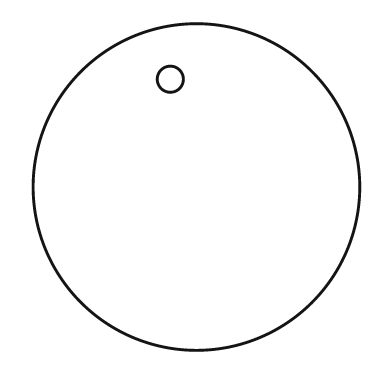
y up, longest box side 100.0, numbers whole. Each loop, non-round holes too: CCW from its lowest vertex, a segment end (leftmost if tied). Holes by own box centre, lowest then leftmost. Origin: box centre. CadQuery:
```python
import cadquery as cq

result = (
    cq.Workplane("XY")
    .moveTo(0.0, 0.0)
    .circle(50.0)
    .moveTo(-8.0, 33.0)
    .circle(4.0)
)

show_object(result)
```